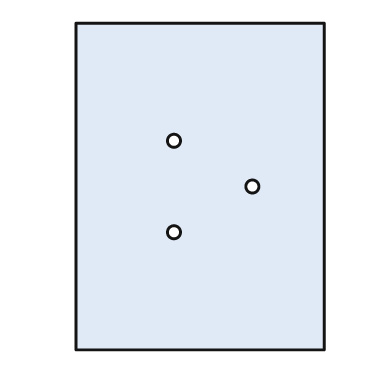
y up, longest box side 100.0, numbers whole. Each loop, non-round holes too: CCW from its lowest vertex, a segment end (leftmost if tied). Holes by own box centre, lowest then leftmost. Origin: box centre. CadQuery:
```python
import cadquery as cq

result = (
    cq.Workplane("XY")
    .moveTo(-38.0, -50.0)
    .lineTo(38.0, -50.0)
    .lineTo(38.0, 50.0)
    .lineTo(-38.0, 50.0)
    .close()
    .moveTo(-8.0, -14.0)
    .circle(2.0)
    .moveTo(16.0, 0.0)
    .circle(2.0)
    .moveTo(-8.0, 14.0)
    .circle(2.0)
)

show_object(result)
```